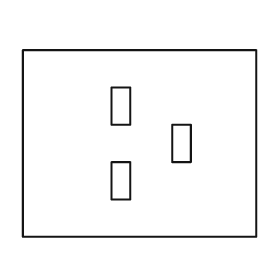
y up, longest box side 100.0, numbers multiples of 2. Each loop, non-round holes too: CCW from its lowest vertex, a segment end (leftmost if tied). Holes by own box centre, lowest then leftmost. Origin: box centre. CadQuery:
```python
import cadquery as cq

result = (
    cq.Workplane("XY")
    .moveTo(-50.0, -40.0)
    .lineTo(50.0, -40.0)
    .lineTo(50.0, 40.0)
    .lineTo(-50.0, 40.0)
    .close()
    .moveTo(-12.0, -24.0)
    .lineTo(-4.0, -24.0)
    .lineTo(-4.0, -8.0)
    .lineTo(-12.0, -8.0)
    .close()
    .moveTo(14.0, -8.0)
    .lineTo(22.0, -8.0)
    .lineTo(22.0, 8.0)
    .lineTo(14.0, 8.0)
    .close()
    .moveTo(-12.0, 8.0)
    .lineTo(-4.0, 8.0)
    .lineTo(-4.0, 24.0)
    .lineTo(-12.0, 24.0)
    .close()
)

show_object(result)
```